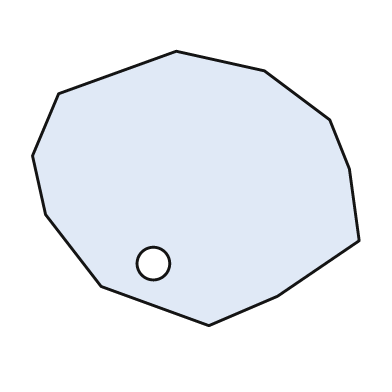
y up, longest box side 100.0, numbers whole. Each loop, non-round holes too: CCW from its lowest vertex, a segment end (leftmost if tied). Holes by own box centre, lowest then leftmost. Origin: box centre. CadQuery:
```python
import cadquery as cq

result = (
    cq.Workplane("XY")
    .moveTo(4.0, -42.0)
    .lineTo(25.0, -33.0)
    .lineTo(50.0, -16.0)
    .lineTo(47.0, 6.0)
    .lineTo(41.0, 21.0)
    .lineTo(21.0, 36.0)
    .lineTo(-6.0, 42.0)
    .lineTo(-42.0, 29.0)
    .lineTo(-50.0, 10.0)
    .lineTo(-46.0, -8.0)
    .lineTo(-29.0, -30.0)
    .close()
    .moveTo(-13.0, -23.0)
    .circle(5.0)
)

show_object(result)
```